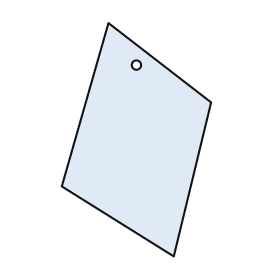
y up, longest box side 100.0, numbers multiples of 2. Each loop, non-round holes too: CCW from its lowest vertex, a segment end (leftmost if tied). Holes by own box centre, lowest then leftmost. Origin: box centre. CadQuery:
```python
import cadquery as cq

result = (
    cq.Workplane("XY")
    .moveTo(16.0, -50.0)
    .lineTo(32.0, 16.0)
    .lineTo(-12.0, 50.0)
    .lineTo(-32.0, -20.0)
    .close()
    .moveTo(0.0, 32.0)
    .circle(2.0)
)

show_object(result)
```